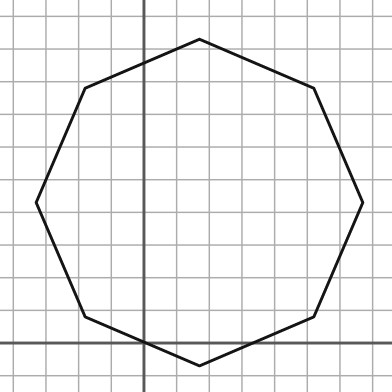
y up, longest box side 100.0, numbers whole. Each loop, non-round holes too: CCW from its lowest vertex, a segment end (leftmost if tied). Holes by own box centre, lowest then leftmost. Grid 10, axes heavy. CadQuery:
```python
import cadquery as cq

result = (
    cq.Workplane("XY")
    .moveTo(17.0, -7.0)
    .lineTo(52.0, 8.0)
    .lineTo(67.0, 43.0)
    .lineTo(52.0, 78.0)
    .lineTo(17.0, 93.0)
    .lineTo(-18.0, 78.0)
    .lineTo(-33.0, 43.0)
    .lineTo(-18.0, 8.0)
    .close()
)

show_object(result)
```